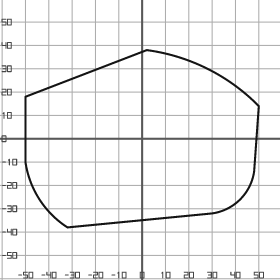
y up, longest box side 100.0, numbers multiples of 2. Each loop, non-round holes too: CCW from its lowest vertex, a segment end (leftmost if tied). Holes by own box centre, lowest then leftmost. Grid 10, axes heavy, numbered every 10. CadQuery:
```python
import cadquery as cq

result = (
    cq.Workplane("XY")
    .moveTo(-32.0, -38.0)
    .lineTo(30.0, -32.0)
    .threePointArc((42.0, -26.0), (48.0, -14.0))
    .lineTo(50.0, 14.0)
    .threePointArc((28.0, 30.0), (2.0, 38.0))
    .lineTo(-50.0, 18.0)
    .lineTo(-50.0, -10.0)
    .threePointArc((-44.0, -26.0), (-32.0, -38.0))
    .close()
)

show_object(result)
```